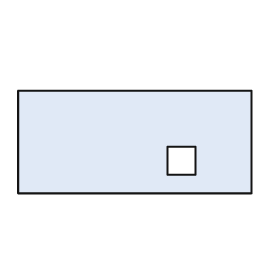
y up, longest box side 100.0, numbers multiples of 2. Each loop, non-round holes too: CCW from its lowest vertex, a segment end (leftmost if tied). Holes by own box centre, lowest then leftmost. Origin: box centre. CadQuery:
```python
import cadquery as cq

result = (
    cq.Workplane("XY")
    .moveTo(-50.0, -22.0)
    .lineTo(50.0, -22.0)
    .lineTo(50.0, 22.0)
    .lineTo(-50.0, 22.0)
    .close()
    .moveTo(14.0, -14.0)
    .lineTo(26.0, -14.0)
    .lineTo(26.0, -2.0)
    .lineTo(14.0, -2.0)
    .close()
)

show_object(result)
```